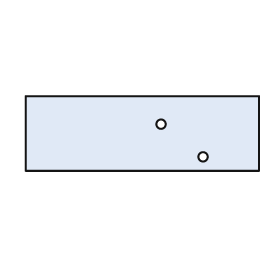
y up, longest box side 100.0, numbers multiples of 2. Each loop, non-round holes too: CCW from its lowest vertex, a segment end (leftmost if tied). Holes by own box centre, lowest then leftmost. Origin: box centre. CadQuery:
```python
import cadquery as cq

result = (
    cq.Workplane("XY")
    .moveTo(-50.0, -16.0)
    .lineTo(50.0, -16.0)
    .lineTo(50.0, 16.0)
    .lineTo(-50.0, 16.0)
    .close()
    .moveTo(26.0, -10.0)
    .circle(2.0)
    .moveTo(8.0, 4.0)
    .circle(2.0)
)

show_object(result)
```